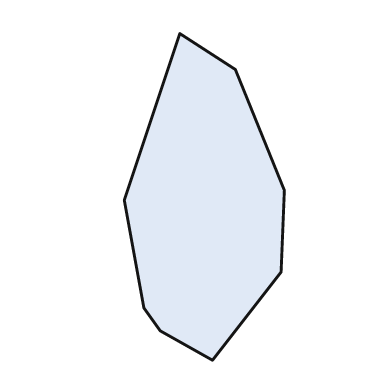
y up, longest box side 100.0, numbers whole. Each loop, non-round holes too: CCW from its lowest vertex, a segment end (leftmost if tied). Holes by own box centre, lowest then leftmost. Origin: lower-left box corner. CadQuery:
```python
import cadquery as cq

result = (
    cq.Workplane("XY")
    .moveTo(27.0, 0.0)
    .lineTo(48.0, 27.0)
    .lineTo(49.0, 52.0)
    .lineTo(34.0, 89.0)
    .lineTo(17.0, 100.0)
    .lineTo(0.0, 49.0)
    .lineTo(6.0, 16.0)
    .lineTo(11.0, 9.0)
    .close()
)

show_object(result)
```